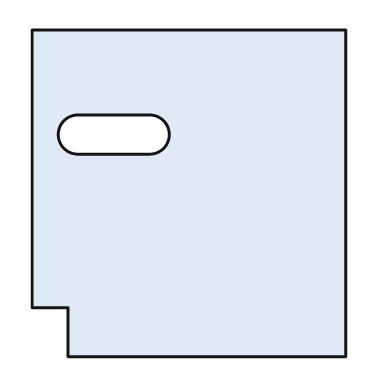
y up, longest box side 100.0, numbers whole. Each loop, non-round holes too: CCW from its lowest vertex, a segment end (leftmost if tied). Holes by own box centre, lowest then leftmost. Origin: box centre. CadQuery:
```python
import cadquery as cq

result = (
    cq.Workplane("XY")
    .moveTo(-37.0, -50.0)
    .lineTo(48.0, -50.0)
    .lineTo(48.0, 50.0)
    .lineTo(-48.0, 50.0)
    .lineTo(-48.0, -35.0)
    .lineTo(-37.0, -35.0)
    .close()
    .moveTo(-34.0, 12.0)
    .lineTo(-12.0, 12.0)
    .threePointArc((-6.0, 18.0), (-12.0, 24.0))
    .lineTo(-34.0, 24.0)
    .threePointArc((-40.0, 18.0), (-34.0, 12.0))
    .close()
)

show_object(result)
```